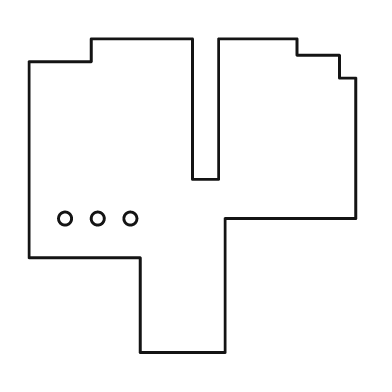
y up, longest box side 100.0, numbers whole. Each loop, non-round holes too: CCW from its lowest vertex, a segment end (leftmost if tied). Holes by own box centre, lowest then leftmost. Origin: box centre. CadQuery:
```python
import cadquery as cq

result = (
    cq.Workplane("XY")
    .moveTo(-16.0, -48.0)
    .lineTo(10.0, -48.0)
    .lineTo(10.0, -7.0)
    .lineTo(50.0, -7.0)
    .lineTo(50.0, 36.0)
    .lineTo(45.0, 36.0)
    .lineTo(45.0, 43.0)
    .lineTo(32.0, 43.0)
    .lineTo(32.0, 48.0)
    .lineTo(8.0, 48.0)
    .lineTo(8.0, 5.0)
    .lineTo(0.0, 5.0)
    .lineTo(0.0, 48.0)
    .lineTo(-31.0, 48.0)
    .lineTo(-31.0, 41.0)
    .lineTo(-50.0, 41.0)
    .lineTo(-50.0, -19.0)
    .lineTo(-16.0, -19.0)
    .close()
    .moveTo(-39.0, -7.0)
    .circle(2.0)
    .moveTo(-29.0, -7.0)
    .circle(2.0)
    .moveTo(-19.0, -7.0)
    .circle(2.0)
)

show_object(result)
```